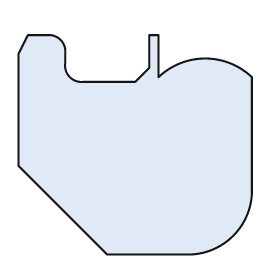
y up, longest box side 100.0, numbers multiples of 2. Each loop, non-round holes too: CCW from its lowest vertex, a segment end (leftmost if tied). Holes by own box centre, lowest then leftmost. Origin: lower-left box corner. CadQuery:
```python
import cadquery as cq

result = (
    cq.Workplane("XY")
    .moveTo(38.0, 0.0)
    .lineTo(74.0, 0.0)
    .threePointArc((92.0, 8.0), (100.0, 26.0))
    .lineTo(100.0, 76.0)
    .threePointArc((80.0, 84.0), (60.0, 76.0))
    .lineTo(60.0, 94.0)
    .lineTo(56.0, 94.0)
    .lineTo(56.0, 80.0)
    .lineTo(50.0, 74.0)
    .lineTo(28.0, 74.0)
    .threePointArc((22.0, 76.0), (20.0, 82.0))
    .lineTo(20.0, 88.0)
    .threePointArc((18.0, 92.0), (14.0, 94.0))
    .lineTo(4.0, 94.0)
    .lineTo(0.0, 86.0)
    .lineTo(0.0, 38.0)
    .close()
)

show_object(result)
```